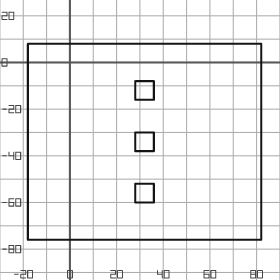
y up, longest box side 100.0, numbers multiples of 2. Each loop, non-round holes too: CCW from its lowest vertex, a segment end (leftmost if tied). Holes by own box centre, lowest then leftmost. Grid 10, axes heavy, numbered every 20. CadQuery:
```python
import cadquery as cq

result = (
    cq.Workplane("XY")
    .moveTo(-18.0, -76.0)
    .lineTo(82.0, -76.0)
    .lineTo(82.0, 8.0)
    .lineTo(-18.0, 8.0)
    .close()
    .moveTo(28.0, -60.0)
    .lineTo(36.0, -60.0)
    .lineTo(36.0, -52.0)
    .lineTo(28.0, -52.0)
    .close()
    .moveTo(28.0, -38.0)
    .lineTo(36.0, -38.0)
    .lineTo(36.0, -30.0)
    .lineTo(28.0, -30.0)
    .close()
    .moveTo(28.0, -16.0)
    .lineTo(36.0, -16.0)
    .lineTo(36.0, -8.0)
    .lineTo(28.0, -8.0)
    .close()
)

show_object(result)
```